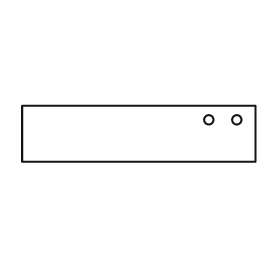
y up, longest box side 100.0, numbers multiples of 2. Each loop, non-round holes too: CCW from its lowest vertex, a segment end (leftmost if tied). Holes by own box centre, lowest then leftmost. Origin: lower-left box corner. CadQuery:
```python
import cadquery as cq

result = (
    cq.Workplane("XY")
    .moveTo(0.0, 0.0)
    .lineTo(100.0, 0.0)
    .lineTo(100.0, 24.0)
    .lineTo(0.0, 24.0)
    .close()
    .moveTo(80.0, 18.0)
    .circle(2.0)
    .moveTo(92.0, 18.0)
    .circle(2.0)
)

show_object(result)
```